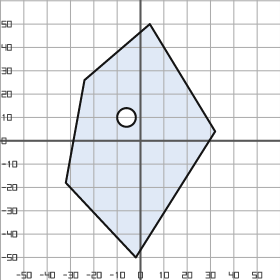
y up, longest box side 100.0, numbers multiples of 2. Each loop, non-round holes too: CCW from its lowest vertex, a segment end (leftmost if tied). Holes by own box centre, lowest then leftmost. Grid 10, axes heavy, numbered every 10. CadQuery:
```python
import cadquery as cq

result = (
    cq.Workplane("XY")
    .moveTo(-2.0, -50.0)
    .lineTo(32.0, 4.0)
    .lineTo(4.0, 50.0)
    .lineTo(-24.0, 26.0)
    .lineTo(-32.0, -18.0)
    .close()
    .moveTo(-6.0, 10.0)
    .circle(4.0)
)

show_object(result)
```